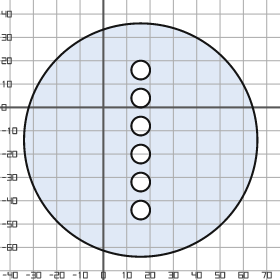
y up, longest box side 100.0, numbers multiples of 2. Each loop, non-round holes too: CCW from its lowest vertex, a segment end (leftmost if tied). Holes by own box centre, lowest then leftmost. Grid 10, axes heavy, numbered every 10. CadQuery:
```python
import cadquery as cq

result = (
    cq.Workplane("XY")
    .moveTo(16.0, -14.0)
    .circle(50.0)
    .moveTo(16.0, -44.0)
    .circle(4.0)
    .moveTo(16.0, -32.0)
    .circle(4.0)
    .moveTo(16.0, -20.0)
    .circle(4.0)
    .moveTo(16.0, -8.0)
    .circle(4.0)
    .moveTo(16.0, 4.0)
    .circle(4.0)
    .moveTo(16.0, 16.0)
    .circle(4.0)
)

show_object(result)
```